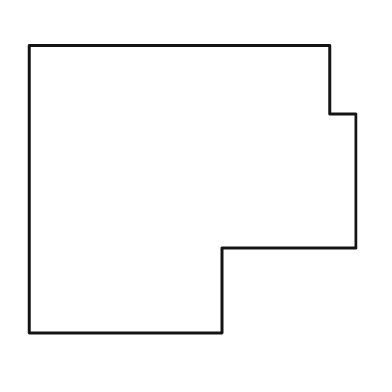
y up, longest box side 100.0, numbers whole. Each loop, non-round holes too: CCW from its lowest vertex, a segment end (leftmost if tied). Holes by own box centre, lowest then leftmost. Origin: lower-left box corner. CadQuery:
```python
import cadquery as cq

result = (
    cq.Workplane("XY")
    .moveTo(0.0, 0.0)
    .lineTo(59.0, 0.0)
    .lineTo(59.0, 26.0)
    .lineTo(100.0, 26.0)
    .lineTo(100.0, 67.0)
    .lineTo(92.0, 67.0)
    .lineTo(92.0, 88.0)
    .lineTo(0.0, 88.0)
    .close()
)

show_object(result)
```